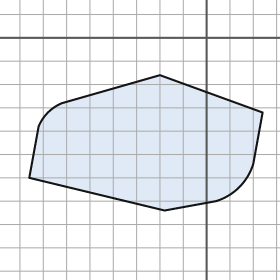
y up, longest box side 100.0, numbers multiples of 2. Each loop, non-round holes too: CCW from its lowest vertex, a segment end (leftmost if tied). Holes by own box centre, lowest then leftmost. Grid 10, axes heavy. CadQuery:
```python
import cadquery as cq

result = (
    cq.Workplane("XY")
    .moveTo(-18.0, -74.0)
    .lineTo(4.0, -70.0)
    .threePointArc((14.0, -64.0), (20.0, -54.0))
    .lineTo(24.0, -32.0)
    .lineTo(-20.0, -16.0)
    .lineTo(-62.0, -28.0)
    .threePointArc((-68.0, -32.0), (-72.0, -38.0))
    .lineTo(-76.0, -60.0)
    .close()
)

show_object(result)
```